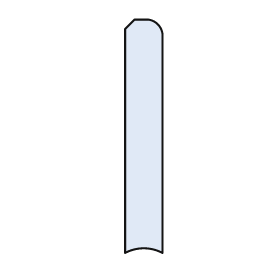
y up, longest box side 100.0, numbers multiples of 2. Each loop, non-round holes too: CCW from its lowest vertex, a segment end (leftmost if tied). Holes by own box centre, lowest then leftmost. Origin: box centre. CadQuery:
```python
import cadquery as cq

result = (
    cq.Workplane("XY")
    .moveTo(-8.0, -50.0)
    .threePointArc((0.0, -48.0), (8.0, -50.0))
    .lineTo(8.0, 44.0)
    .threePointArc((6.0, 48.0), (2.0, 50.0))
    .lineTo(-4.0, 50.0)
    .lineTo(-8.0, 46.0)
    .close()
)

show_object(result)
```